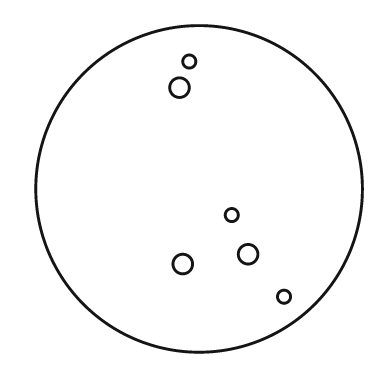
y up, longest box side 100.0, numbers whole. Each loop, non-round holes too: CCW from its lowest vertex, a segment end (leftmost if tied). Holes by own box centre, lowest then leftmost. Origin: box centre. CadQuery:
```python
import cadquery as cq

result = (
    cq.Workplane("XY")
    .moveTo(0.0, 0.0)
    .circle(50.0)
    .moveTo(26.0, -33.0)
    .circle(2.0)
    .moveTo(-5.0, -23.0)
    .circle(3.0)
    .moveTo(15.0, -20.0)
    .circle(3.0)
    .moveTo(10.0, -8.0)
    .circle(2.0)
    .moveTo(-6.0, 31.0)
    .circle(3.0)
    .moveTo(-3.0, 39.0)
    .circle(2.0)
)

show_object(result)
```